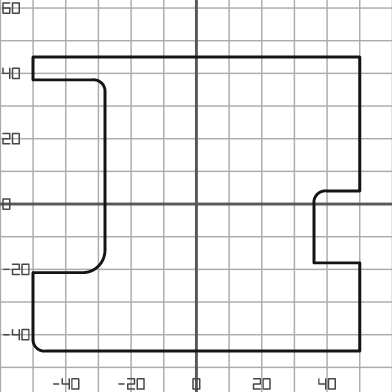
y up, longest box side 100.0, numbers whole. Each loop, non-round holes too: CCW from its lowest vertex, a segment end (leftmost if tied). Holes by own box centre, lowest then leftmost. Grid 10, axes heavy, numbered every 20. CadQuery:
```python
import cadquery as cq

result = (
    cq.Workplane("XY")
    .moveTo(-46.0, -45.0)
    .lineTo(50.0, -45.0)
    .lineTo(50.0, -18.0)
    .lineTo(36.0, -18.0)
    .lineTo(36.0, 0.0)
    .threePointArc((37.0, 3.0), (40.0, 4.0))
    .lineTo(50.0, 4.0)
    .lineTo(50.0, 45.0)
    .lineTo(-50.0, 45.0)
    .lineTo(-50.0, 38.0)
    .lineTo(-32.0, 38.0)
    .threePointArc((-29.0, 37.0), (-28.0, 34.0))
    .lineTo(-28.0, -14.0)
    .threePointArc((-30.0, -19.0), (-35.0, -21.0))
    .lineTo(-50.0, -21.0)
    .lineTo(-50.0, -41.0)
    .threePointArc((-49.0, -44.0), (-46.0, -45.0))
    .close()
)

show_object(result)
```